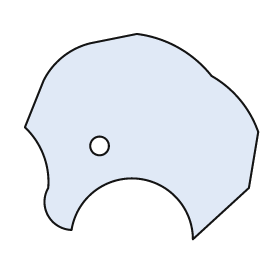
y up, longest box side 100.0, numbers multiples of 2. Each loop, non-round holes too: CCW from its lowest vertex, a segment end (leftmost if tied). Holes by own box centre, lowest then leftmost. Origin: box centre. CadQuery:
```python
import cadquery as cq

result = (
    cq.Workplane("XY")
    .moveTo(22.0, -44.0)
    .lineTo(46.0, -22.0)
    .lineTo(50.0, 2.0)
    .threePointArc((42.0, 16.0), (30.0, 26.0))
    .threePointArc((16.0, 38.0), (-2.0, 44.0))
    .lineTo(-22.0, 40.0)
    .threePointArc((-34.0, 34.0), (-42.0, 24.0))
    .lineTo(-50.0, 4.0)
    .threePointArc((-42.0, -8.0), (-40.0, -22.0))
    .threePointArc((-40.0, -34.0), (-30.0, -40.0))
    .threePointArc((-2.0, -18.0), (22.0, -44.0))
    .close()
    .moveTo(-18.0, -4.0)
    .circle(4.0)
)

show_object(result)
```